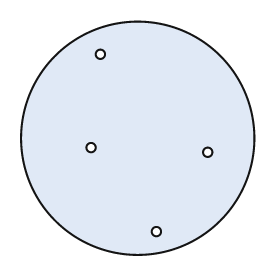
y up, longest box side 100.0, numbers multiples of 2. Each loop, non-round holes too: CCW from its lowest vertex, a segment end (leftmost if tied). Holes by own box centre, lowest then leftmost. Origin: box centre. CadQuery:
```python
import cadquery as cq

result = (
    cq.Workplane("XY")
    .moveTo(0.0, 0.0)
    .circle(50.0)
    .moveTo(8.0, -40.0)
    .circle(2.0)
    .moveTo(30.0, -6.0)
    .circle(2.0)
    .moveTo(-20.0, -4.0)
    .circle(2.0)
    .moveTo(-16.0, 36.0)
    .circle(2.0)
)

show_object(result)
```